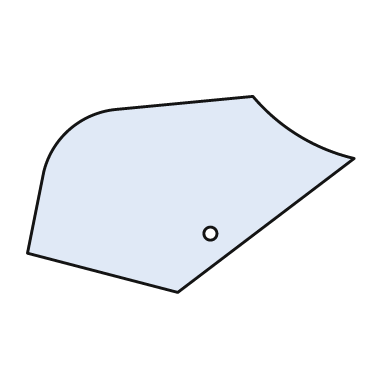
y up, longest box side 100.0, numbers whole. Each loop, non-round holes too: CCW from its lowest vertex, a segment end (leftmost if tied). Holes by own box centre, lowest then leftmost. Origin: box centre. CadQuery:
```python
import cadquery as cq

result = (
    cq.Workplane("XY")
    .moveTo(-4.0, -30.0)
    .lineTo(50.0, 11.0)
    .threePointArc((33.0, 18.0), (19.0, 30.0))
    .lineTo(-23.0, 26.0)
    .threePointArc((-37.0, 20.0), (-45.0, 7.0))
    .lineTo(-50.0, -18.0)
    .close()
    .moveTo(6.0, -12.0)
    .circle(2.0)
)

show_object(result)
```